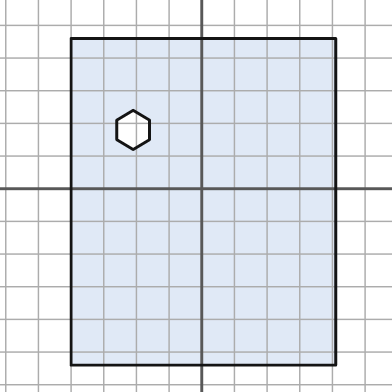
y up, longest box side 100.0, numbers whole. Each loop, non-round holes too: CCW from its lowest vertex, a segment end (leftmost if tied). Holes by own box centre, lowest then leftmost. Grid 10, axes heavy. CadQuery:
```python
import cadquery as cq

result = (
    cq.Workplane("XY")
    .moveTo(-40.0, -54.0)
    .lineTo(41.0, -54.0)
    .lineTo(41.0, 46.0)
    .lineTo(-40.0, 46.0)
    .close()
    .moveTo(-21.0, 12.0)
    .lineTo(-16.0, 15.0)
    .lineTo(-16.0, 21.0)
    .lineTo(-21.0, 24.0)
    .lineTo(-26.0, 21.0)
    .lineTo(-26.0, 15.0)
    .close()
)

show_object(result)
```